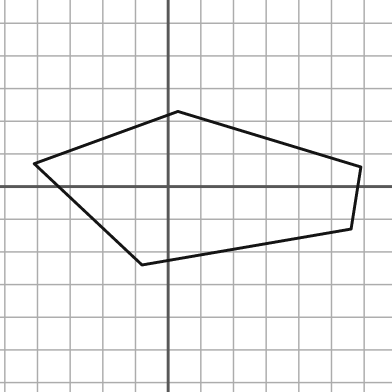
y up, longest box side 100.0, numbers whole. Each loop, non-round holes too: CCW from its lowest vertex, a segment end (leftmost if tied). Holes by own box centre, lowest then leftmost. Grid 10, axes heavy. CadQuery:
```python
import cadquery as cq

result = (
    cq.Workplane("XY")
    .moveTo(-8.0, -24.0)
    .lineTo(56.0, -13.0)
    .lineTo(59.0, 6.0)
    .lineTo(3.0, 23.0)
    .lineTo(-41.0, 7.0)
    .close()
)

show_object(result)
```